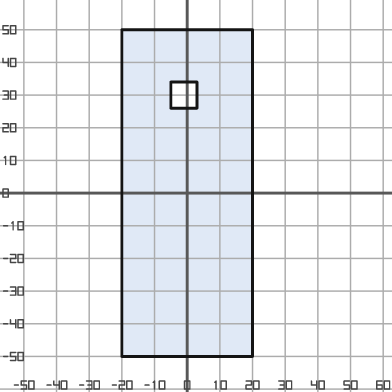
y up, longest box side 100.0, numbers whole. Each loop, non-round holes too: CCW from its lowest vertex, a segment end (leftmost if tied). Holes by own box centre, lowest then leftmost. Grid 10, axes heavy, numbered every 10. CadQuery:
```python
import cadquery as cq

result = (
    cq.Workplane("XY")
    .moveTo(-20.0, -50.0)
    .lineTo(20.0, -50.0)
    .lineTo(20.0, 50.0)
    .lineTo(-20.0, 50.0)
    .close()
    .moveTo(-5.0, 26.0)
    .lineTo(3.0, 26.0)
    .lineTo(3.0, 34.0)
    .lineTo(-5.0, 34.0)
    .close()
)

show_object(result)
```